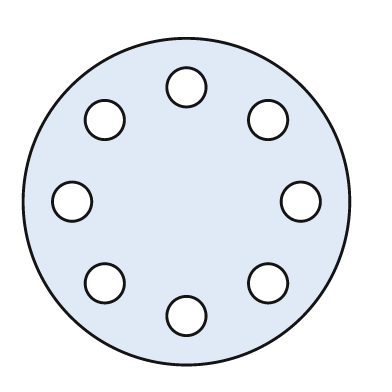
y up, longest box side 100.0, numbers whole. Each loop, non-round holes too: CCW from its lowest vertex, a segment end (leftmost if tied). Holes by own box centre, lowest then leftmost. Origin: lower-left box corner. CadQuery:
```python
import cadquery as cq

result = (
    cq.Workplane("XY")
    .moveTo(50.0, 50.0)
    .circle(50.0)
    .moveTo(50.0, 15.0)
    .circle(6.0)
    .moveTo(25.0, 25.0)
    .circle(6.0)
    .moveTo(75.0, 25.0)
    .circle(6.0)
    .moveTo(15.0, 50.0)
    .circle(6.0)
    .moveTo(85.0, 50.0)
    .circle(6.0)
    .moveTo(25.0, 75.0)
    .circle(6.0)
    .moveTo(75.0, 75.0)
    .circle(6.0)
    .moveTo(50.0, 85.0)
    .circle(6.0)
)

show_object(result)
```